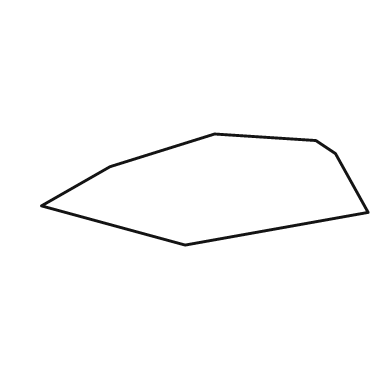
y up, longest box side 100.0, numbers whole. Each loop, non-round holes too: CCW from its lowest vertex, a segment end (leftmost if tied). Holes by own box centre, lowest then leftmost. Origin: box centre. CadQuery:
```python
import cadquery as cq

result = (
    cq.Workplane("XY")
    .moveTo(-6.0, -17.0)
    .lineTo(50.0, -7.0)
    .lineTo(40.0, 11.0)
    .lineTo(34.0, 15.0)
    .lineTo(3.0, 17.0)
    .lineTo(-29.0, 7.0)
    .lineTo(-50.0, -5.0)
    .close()
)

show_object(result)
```